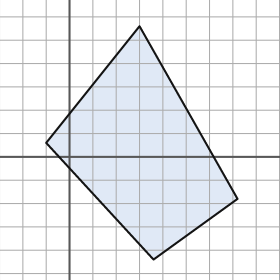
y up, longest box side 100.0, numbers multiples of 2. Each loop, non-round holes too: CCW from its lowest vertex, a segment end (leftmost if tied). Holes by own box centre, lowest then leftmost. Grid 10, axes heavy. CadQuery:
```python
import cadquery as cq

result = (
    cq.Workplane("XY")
    .moveTo(36.0, -44.0)
    .lineTo(72.0, -18.0)
    .lineTo(30.0, 56.0)
    .lineTo(-10.0, 6.0)
    .close()
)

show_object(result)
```